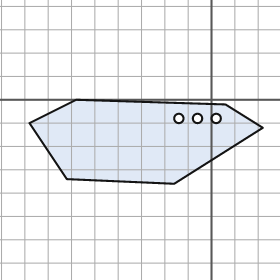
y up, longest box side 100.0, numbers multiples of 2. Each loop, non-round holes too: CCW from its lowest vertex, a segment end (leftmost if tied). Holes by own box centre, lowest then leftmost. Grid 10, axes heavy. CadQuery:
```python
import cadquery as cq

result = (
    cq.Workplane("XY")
    .moveTo(-16.0, -36.0)
    .lineTo(22.0, -12.0)
    .lineTo(6.0, -2.0)
    .lineTo(-58.0, 0.0)
    .lineTo(-78.0, -10.0)
    .lineTo(-62.0, -34.0)
    .close()
    .moveTo(-14.0, -8.0)
    .circle(2.0)
    .moveTo(-6.0, -8.0)
    .circle(2.0)
    .moveTo(2.0, -8.0)
    .circle(2.0)
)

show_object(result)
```